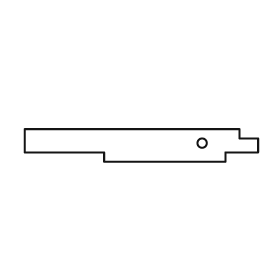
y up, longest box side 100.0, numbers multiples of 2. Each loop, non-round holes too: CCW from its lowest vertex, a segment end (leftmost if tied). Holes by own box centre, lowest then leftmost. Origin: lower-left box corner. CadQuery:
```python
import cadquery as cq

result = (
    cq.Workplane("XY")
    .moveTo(34.0, 0.0)
    .lineTo(86.0, 0.0)
    .lineTo(86.0, 4.0)
    .lineTo(100.0, 4.0)
    .lineTo(100.0, 10.0)
    .lineTo(92.0, 10.0)
    .lineTo(92.0, 14.0)
    .lineTo(0.0, 14.0)
    .lineTo(0.0, 4.0)
    .lineTo(34.0, 4.0)
    .close()
    .moveTo(76.0, 8.0)
    .circle(2.0)
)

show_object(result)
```